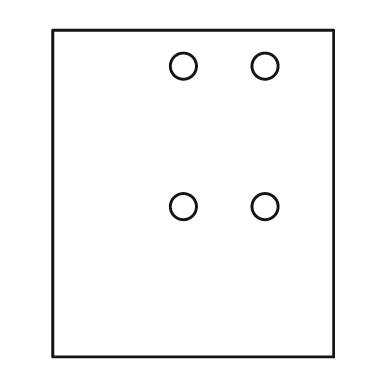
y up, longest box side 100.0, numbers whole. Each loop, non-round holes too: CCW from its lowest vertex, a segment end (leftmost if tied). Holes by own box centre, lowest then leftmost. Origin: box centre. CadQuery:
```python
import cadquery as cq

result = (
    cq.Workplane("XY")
    .moveTo(-43.0, -50.0)
    .lineTo(43.0, -50.0)
    .lineTo(43.0, 50.0)
    .lineTo(-43.0, 50.0)
    .close()
    .moveTo(-3.0, -4.0)
    .circle(4.0)
    .moveTo(22.0, -4.0)
    .circle(4.0)
    .moveTo(-3.0, 39.0)
    .circle(4.0)
    .moveTo(22.0, 39.0)
    .circle(4.0)
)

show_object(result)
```